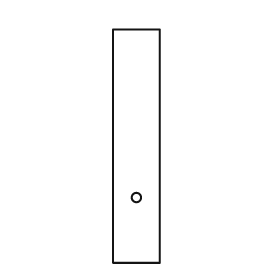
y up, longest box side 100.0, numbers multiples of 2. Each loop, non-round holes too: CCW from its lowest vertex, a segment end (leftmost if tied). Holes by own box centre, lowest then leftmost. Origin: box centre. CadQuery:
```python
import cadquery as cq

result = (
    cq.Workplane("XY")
    .moveTo(-10.0, -50.0)
    .lineTo(10.0, -50.0)
    .lineTo(10.0, 50.0)
    .lineTo(-10.0, 50.0)
    .close()
    .moveTo(0.0, -22.0)
    .circle(2.0)
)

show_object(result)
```